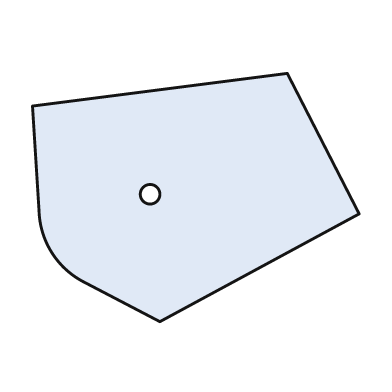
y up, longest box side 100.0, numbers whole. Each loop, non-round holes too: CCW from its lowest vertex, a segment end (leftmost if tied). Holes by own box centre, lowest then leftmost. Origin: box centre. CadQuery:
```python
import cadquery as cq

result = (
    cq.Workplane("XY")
    .moveTo(-11.0, -38.0)
    .lineTo(50.0, -5.0)
    .lineTo(28.0, 38.0)
    .lineTo(-50.0, 28.0)
    .lineTo(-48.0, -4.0)
    .threePointArc((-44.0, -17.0), (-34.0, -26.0))
    .close()
    .moveTo(-14.0, 1.0)
    .circle(3.0)
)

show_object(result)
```